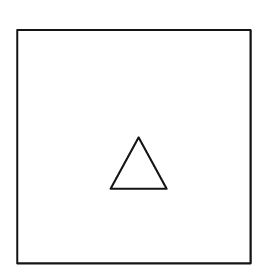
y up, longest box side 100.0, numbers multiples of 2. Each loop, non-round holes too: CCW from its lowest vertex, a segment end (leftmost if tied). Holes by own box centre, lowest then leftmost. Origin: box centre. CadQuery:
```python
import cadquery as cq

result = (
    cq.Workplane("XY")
    .moveTo(-50.0, -50.0)
    .lineTo(50.0, -50.0)
    .lineTo(50.0, 50.0)
    .lineTo(-50.0, 50.0)
    .close()
    .moveTo(-10.0, -18.0)
    .lineTo(14.0, -18.0)
    .lineTo(2.0, 4.0)
    .close()
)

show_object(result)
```